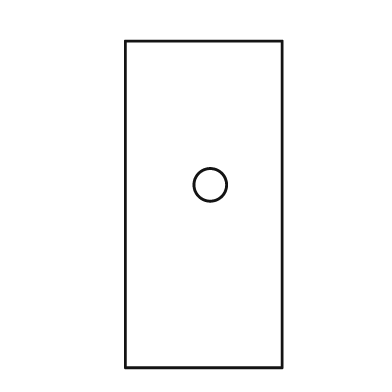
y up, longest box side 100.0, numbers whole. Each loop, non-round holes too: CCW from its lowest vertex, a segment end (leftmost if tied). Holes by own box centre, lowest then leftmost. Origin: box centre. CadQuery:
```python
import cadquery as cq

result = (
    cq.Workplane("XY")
    .moveTo(-24.0, -50.0)
    .lineTo(24.0, -50.0)
    .lineTo(24.0, 50.0)
    .lineTo(-24.0, 50.0)
    .close()
    .moveTo(2.0, 6.0)
    .circle(5.0)
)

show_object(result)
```